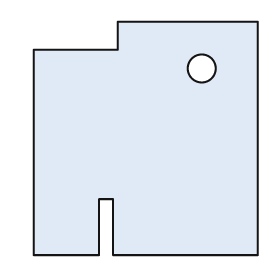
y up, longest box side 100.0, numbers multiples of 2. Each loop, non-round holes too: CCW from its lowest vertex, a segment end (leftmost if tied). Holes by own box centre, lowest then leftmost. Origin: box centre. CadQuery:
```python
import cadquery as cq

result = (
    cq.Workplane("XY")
    .moveTo(-48.0, -50.0)
    .lineTo(-20.0, -50.0)
    .lineTo(-20.0, -26.0)
    .lineTo(-14.0, -26.0)
    .lineTo(-14.0, -50.0)
    .lineTo(48.0, -50.0)
    .lineTo(48.0, 50.0)
    .lineTo(-12.0, 50.0)
    .lineTo(-12.0, 38.0)
    .lineTo(-48.0, 38.0)
    .close()
    .moveTo(24.0, 30.0)
    .circle(6.0)
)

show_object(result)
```